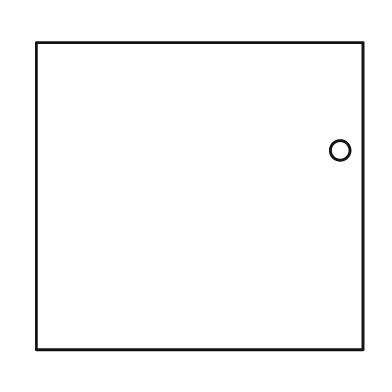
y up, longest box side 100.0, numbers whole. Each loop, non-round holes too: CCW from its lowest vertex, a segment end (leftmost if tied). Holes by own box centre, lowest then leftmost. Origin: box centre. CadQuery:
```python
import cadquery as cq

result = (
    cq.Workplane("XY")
    .moveTo(-50.0, -47.0)
    .lineTo(50.0, -47.0)
    .lineTo(50.0, 47.0)
    .lineTo(-50.0, 47.0)
    .close()
    .moveTo(43.0, 14.0)
    .circle(3.0)
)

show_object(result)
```